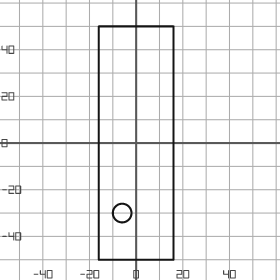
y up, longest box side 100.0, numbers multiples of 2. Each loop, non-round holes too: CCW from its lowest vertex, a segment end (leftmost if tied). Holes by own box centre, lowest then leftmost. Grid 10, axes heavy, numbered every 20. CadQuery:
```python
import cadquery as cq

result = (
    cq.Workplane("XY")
    .moveTo(-16.0, -50.0)
    .lineTo(16.0, -50.0)
    .lineTo(16.0, 50.0)
    .lineTo(-16.0, 50.0)
    .close()
    .moveTo(-6.0, -30.0)
    .circle(4.0)
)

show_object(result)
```